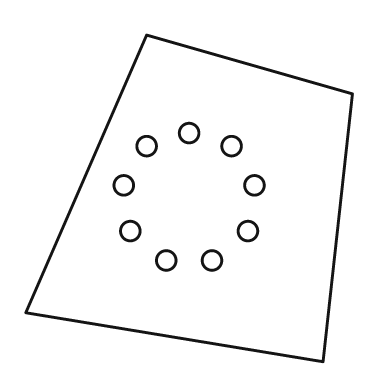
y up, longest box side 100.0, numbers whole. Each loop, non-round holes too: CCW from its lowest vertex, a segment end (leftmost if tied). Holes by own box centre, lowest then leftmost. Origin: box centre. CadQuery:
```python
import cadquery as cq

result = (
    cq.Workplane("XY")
    .moveTo(41.0, -50.0)
    .lineTo(50.0, 32.0)
    .lineTo(-13.0, 50.0)
    .lineTo(-50.0, -35.0)
    .close()
    .moveTo(-7.0, -19.0)
    .circle(3.0)
    .moveTo(7.0, -19.0)
    .circle(3.0)
    .moveTo(-18.0, -10.0)
    .circle(3.0)
    .moveTo(18.0, -10.0)
    .circle(3.0)
    .moveTo(-20.0, 4.0)
    .circle(3.0)
    .moveTo(20.0, 4.0)
    .circle(3.0)
    .moveTo(-13.0, 16.0)
    .circle(3.0)
    .moveTo(13.0, 16.0)
    .circle(3.0)
    .moveTo(0.0, 20.0)
    .circle(3.0)
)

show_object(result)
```